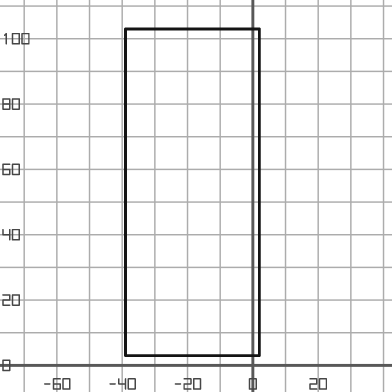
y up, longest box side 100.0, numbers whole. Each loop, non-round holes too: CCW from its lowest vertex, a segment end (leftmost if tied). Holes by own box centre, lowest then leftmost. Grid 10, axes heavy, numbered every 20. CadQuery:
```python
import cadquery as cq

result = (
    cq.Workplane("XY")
    .moveTo(-39.0, 3.0)
    .lineTo(2.0, 3.0)
    .lineTo(2.0, 103.0)
    .lineTo(-39.0, 103.0)
    .close()
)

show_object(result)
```